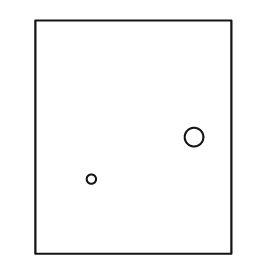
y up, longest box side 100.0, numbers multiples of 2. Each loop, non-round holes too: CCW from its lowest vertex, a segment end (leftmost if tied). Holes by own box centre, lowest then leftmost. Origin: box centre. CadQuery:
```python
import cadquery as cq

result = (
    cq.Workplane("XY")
    .moveTo(-42.0, -50.0)
    .lineTo(42.0, -50.0)
    .lineTo(42.0, 50.0)
    .lineTo(-42.0, 50.0)
    .close()
    .moveTo(-18.0, -18.0)
    .circle(2.0)
    .moveTo(26.0, 0.0)
    .circle(4.0)
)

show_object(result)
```